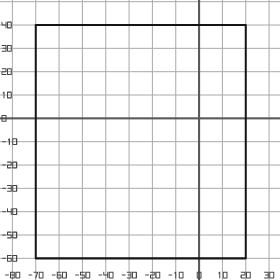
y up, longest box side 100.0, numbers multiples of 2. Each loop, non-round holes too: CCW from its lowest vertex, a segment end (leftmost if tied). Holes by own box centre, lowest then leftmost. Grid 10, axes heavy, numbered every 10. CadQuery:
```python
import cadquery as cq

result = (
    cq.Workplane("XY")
    .moveTo(-70.0, -60.0)
    .lineTo(20.0, -60.0)
    .lineTo(20.0, 40.0)
    .lineTo(-70.0, 40.0)
    .close()
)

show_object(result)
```